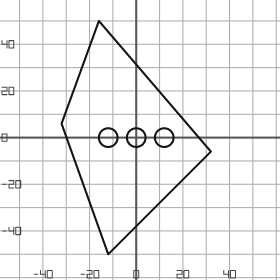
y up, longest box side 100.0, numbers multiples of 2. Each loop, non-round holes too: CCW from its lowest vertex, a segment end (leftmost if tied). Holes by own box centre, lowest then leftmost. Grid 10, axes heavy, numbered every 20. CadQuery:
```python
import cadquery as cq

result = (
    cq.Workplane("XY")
    .moveTo(-12.0, -50.0)
    .lineTo(32.0, -6.0)
    .lineTo(-16.0, 50.0)
    .lineTo(-32.0, 6.0)
    .close()
    .moveTo(-12.0, 0.0)
    .circle(4.0)
    .moveTo(0.0, 0.0)
    .circle(4.0)
    .moveTo(12.0, 0.0)
    .circle(4.0)
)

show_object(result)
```